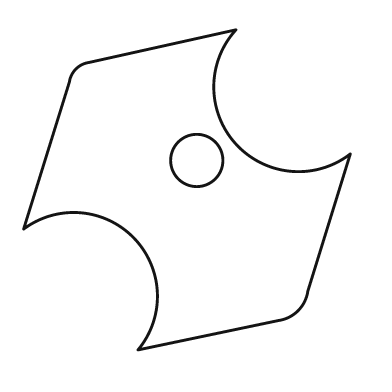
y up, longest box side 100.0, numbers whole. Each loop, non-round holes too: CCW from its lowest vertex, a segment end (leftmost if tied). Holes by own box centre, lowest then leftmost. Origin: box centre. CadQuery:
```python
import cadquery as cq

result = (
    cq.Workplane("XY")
    .moveTo(-15.0, -49.0)
    .lineTo(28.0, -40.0)
    .threePointArc((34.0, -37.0), (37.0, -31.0))
    .lineTo(50.0, 11.0)
    .threePointArc((15.0, 14.0), (15.0, 49.0))
    .lineTo(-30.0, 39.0)
    .threePointArc((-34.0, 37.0), (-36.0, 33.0))
    .lineTo(-50.0, -12.0)
    .threePointArc((-16.0, -15.0), (-15.0, -49.0))
    .close()
    .moveTo(3.0, 9.0)
    .circle(8.0)
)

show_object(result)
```